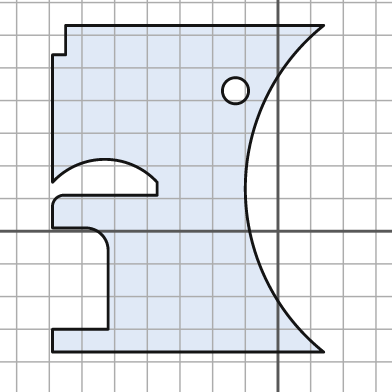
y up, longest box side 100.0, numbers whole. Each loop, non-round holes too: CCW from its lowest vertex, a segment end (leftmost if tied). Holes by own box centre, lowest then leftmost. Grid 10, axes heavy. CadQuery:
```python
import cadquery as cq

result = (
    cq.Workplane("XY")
    .moveTo(-69.0, -37.0)
    .lineTo(14.0, -37.0)
    .threePointArc((-10.0, 13.0), (14.0, 63.0))
    .lineTo(-65.0, 63.0)
    .lineTo(-65.0, 54.0)
    .lineTo(-69.0, 54.0)
    .lineTo(-69.0, 15.0)
    .threePointArc((-53.0, 22.0), (-37.0, 15.0))
    .lineTo(-37.0, 11.0)
    .lineTo(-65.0, 11.0)
    .threePointArc((-68.0, 10.0), (-69.0, 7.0))
    .lineTo(-69.0, 1.0)
    .lineTo(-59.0, 1.0)
    .threePointArc((-54.0, -1.0), (-52.0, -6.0))
    .lineTo(-52.0, -30.0)
    .lineTo(-69.0, -30.0)
    .close()
    .moveTo(-13.0, 43.0)
    .circle(4.0)
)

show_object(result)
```